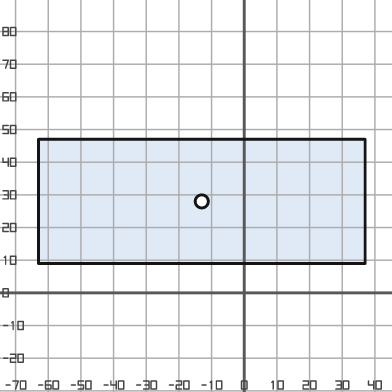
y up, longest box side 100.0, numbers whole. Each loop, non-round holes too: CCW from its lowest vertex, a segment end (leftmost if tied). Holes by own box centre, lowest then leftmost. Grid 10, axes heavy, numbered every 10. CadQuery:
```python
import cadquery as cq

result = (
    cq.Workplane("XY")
    .moveTo(-63.0, 9.0)
    .lineTo(37.0, 9.0)
    .lineTo(37.0, 47.0)
    .lineTo(-63.0, 47.0)
    .close()
    .moveTo(-13.0, 28.0)
    .circle(2.0)
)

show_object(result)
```